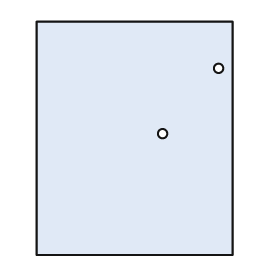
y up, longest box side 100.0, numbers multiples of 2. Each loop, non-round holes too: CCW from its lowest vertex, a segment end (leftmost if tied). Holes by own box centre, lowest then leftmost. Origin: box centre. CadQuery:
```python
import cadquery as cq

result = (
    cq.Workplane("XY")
    .moveTo(-42.0, -50.0)
    .lineTo(42.0, -50.0)
    .lineTo(42.0, 50.0)
    .lineTo(-42.0, 50.0)
    .close()
    .moveTo(12.0, 2.0)
    .circle(2.0)
    .moveTo(36.0, 30.0)
    .circle(2.0)
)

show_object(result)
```